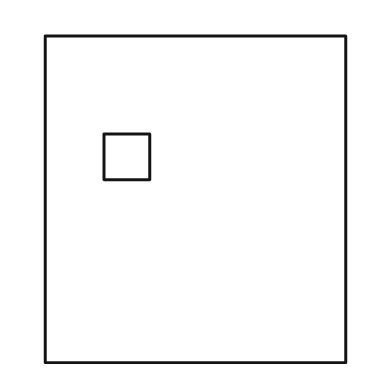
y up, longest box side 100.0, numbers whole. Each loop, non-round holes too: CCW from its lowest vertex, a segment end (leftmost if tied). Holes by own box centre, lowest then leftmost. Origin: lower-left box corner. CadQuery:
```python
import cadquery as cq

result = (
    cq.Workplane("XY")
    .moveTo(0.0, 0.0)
    .lineTo(92.0, 0.0)
    .lineTo(92.0, 100.0)
    .lineTo(0.0, 100.0)
    .close()
    .moveTo(18.0, 56.0)
    .lineTo(32.0, 56.0)
    .lineTo(32.0, 70.0)
    .lineTo(18.0, 70.0)
    .close()
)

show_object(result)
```